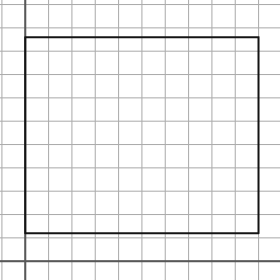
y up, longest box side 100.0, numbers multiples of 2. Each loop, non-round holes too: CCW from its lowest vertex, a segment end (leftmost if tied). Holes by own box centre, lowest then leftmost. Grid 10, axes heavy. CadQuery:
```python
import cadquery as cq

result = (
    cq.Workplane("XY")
    .moveTo(0.0, 12.0)
    .lineTo(100.0, 12.0)
    .lineTo(100.0, 96.0)
    .lineTo(0.0, 96.0)
    .close()
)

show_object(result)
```